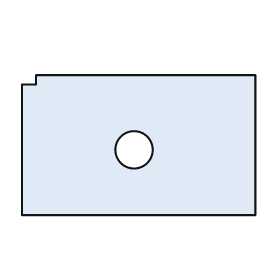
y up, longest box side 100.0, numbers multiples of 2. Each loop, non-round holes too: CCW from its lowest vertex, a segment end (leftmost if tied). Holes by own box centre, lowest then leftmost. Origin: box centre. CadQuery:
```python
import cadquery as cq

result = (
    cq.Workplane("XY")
    .moveTo(-50.0, -30.0)
    .lineTo(50.0, -30.0)
    .lineTo(50.0, 30.0)
    .lineTo(-44.0, 30.0)
    .lineTo(-44.0, 26.0)
    .lineTo(-50.0, 26.0)
    .close()
    .moveTo(-2.0, -2.0)
    .circle(8.0)
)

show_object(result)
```